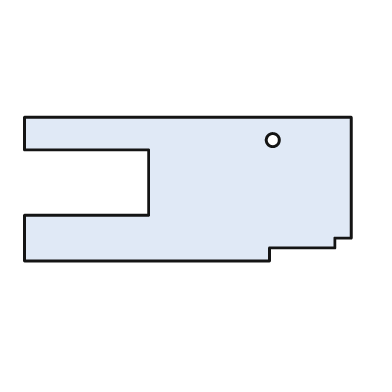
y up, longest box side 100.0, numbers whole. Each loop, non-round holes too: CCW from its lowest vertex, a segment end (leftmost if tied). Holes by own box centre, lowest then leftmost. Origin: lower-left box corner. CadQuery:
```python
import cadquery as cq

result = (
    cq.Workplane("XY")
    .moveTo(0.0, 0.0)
    .lineTo(75.0, 0.0)
    .lineTo(75.0, 4.0)
    .lineTo(95.0, 4.0)
    .lineTo(95.0, 7.0)
    .lineTo(100.0, 7.0)
    .lineTo(100.0, 44.0)
    .lineTo(0.0, 44.0)
    .lineTo(0.0, 34.0)
    .lineTo(38.0, 34.0)
    .lineTo(38.0, 14.0)
    .lineTo(0.0, 14.0)
    .close()
    .moveTo(76.0, 37.0)
    .circle(2.0)
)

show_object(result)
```